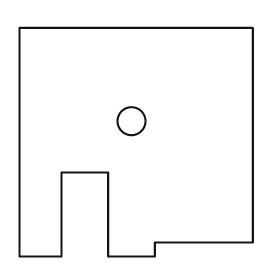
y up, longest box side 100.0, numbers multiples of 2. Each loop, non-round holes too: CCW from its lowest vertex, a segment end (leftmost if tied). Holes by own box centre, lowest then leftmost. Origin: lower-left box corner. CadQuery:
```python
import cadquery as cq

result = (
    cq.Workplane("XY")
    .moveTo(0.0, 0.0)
    .lineTo(18.0, 0.0)
    .lineTo(18.0, 36.0)
    .lineTo(38.0, 36.0)
    .lineTo(38.0, 0.0)
    .lineTo(58.0, 0.0)
    .lineTo(58.0, 6.0)
    .lineTo(100.0, 6.0)
    .lineTo(100.0, 98.0)
    .lineTo(0.0, 98.0)
    .close()
    .moveTo(48.0, 58.0)
    .circle(6.0)
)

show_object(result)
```